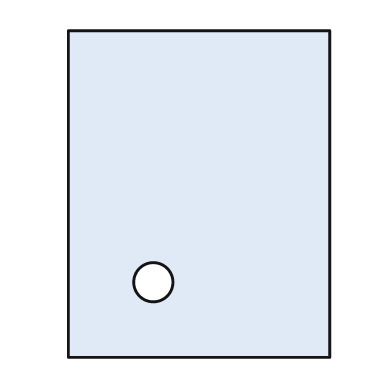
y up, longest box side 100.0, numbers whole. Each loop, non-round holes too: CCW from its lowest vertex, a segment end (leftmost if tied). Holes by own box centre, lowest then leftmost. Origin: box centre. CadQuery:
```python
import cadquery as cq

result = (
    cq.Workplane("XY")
    .moveTo(-40.0, -50.0)
    .lineTo(40.0, -50.0)
    .lineTo(40.0, 50.0)
    .lineTo(-40.0, 50.0)
    .close()
    .moveTo(-14.0, -27.0)
    .circle(6.0)
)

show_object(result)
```